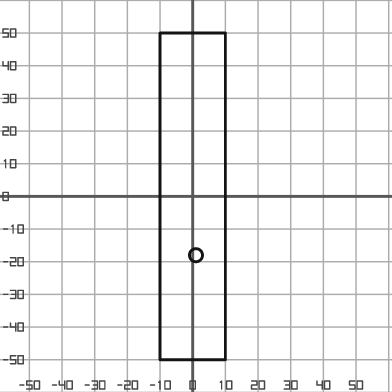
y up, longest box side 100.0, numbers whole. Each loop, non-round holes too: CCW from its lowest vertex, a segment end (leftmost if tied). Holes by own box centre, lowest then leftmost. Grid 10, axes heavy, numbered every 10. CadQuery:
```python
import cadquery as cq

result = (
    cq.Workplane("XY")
    .moveTo(-10.0, -50.0)
    .lineTo(10.0, -50.0)
    .lineTo(10.0, 50.0)
    .lineTo(-10.0, 50.0)
    .close()
    .moveTo(1.0, -18.0)
    .circle(2.0)
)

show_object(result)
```